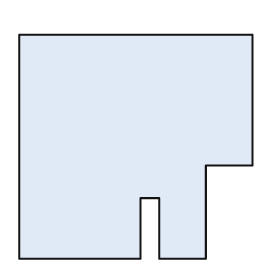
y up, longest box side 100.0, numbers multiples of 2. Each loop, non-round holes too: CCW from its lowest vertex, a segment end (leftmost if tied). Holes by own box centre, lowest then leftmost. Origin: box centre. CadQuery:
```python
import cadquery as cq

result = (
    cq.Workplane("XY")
    .moveTo(-50.0, -48.0)
    .lineTo(2.0, -48.0)
    .lineTo(2.0, -22.0)
    .lineTo(10.0, -22.0)
    .lineTo(10.0, -48.0)
    .lineTo(30.0, -48.0)
    .lineTo(30.0, -8.0)
    .lineTo(50.0, -8.0)
    .lineTo(50.0, 48.0)
    .lineTo(-50.0, 48.0)
    .close()
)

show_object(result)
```